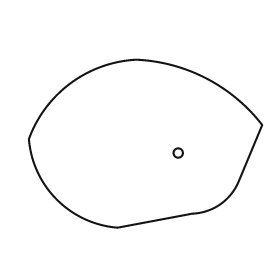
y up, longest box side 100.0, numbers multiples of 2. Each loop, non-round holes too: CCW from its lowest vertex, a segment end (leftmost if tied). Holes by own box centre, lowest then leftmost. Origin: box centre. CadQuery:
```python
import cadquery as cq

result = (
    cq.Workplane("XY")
    .moveTo(-12.0, -36.0)
    .lineTo(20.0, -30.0)
    .threePointArc((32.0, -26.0), (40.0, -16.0))
    .lineTo(50.0, 8.0)
    .threePointArc((26.0, 28.0), (-4.0, 36.0))
    .threePointArc((-32.0, 26.0), (-50.0, 2.0))
    .threePointArc((-38.0, -24.0), (-12.0, -36.0))
    .close()
    .moveTo(14.0, -4.0)
    .circle(2.0)
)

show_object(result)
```